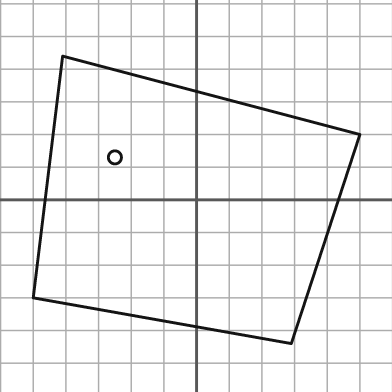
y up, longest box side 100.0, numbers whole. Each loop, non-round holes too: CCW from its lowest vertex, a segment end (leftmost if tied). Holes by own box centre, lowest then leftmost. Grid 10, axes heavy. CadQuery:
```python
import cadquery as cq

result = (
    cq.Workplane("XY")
    .moveTo(29.0, -44.0)
    .lineTo(50.0, 20.0)
    .lineTo(-41.0, 44.0)
    .lineTo(-50.0, -30.0)
    .close()
    .moveTo(-25.0, 13.0)
    .circle(2.0)
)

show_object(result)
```